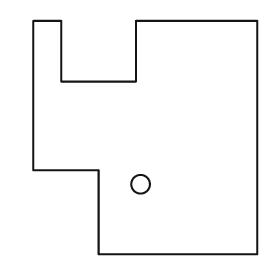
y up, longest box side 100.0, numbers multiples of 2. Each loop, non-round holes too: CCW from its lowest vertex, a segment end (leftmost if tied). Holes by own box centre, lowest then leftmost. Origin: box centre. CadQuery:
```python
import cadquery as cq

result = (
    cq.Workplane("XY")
    .moveTo(-20.0, -50.0)
    .lineTo(48.0, -50.0)
    .lineTo(48.0, 50.0)
    .lineTo(-4.0, 50.0)
    .lineTo(-4.0, 24.0)
    .lineTo(-36.0, 24.0)
    .lineTo(-36.0, 50.0)
    .lineTo(-48.0, 50.0)
    .lineTo(-48.0, -14.0)
    .lineTo(-20.0, -14.0)
    .close()
    .moveTo(-2.0, -20.0)
    .circle(4.0)
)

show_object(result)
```